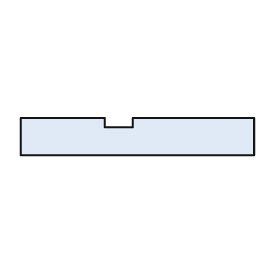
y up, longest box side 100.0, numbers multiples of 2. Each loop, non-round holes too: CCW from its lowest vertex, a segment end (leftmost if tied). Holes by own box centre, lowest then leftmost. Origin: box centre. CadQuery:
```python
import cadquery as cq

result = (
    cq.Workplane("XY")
    .moveTo(-50.0, -8.0)
    .lineTo(50.0, -8.0)
    .lineTo(50.0, 8.0)
    .lineTo(-2.0, 8.0)
    .lineTo(-2.0, 4.0)
    .lineTo(-14.0, 4.0)
    .lineTo(-14.0, 8.0)
    .lineTo(-50.0, 8.0)
    .close()
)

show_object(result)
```